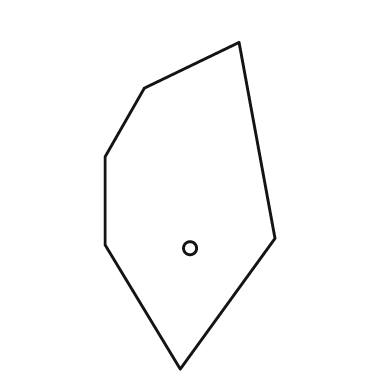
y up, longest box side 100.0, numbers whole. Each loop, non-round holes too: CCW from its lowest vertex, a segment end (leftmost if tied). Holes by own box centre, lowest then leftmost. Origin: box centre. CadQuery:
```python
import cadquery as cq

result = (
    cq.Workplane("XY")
    .moveTo(-3.0, -50.0)
    .lineTo(26.0, -10.0)
    .lineTo(15.0, 50.0)
    .lineTo(-14.0, 36.0)
    .lineTo(-26.0, 15.0)
    .lineTo(-26.0, -12.0)
    .close()
    .moveTo(0.0, -13.0)
    .circle(2.0)
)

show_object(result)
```